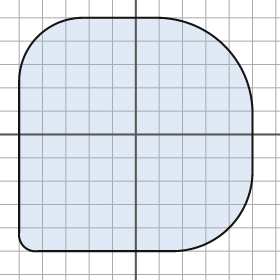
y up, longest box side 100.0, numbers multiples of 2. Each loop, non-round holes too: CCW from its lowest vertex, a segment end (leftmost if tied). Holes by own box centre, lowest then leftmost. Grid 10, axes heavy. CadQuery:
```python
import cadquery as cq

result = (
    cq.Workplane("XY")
    .moveTo(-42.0, -50.0)
    .lineTo(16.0, -50.0)
    .threePointArc((40.0, -40.0), (50.0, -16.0))
    .lineTo(50.0, 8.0)
    .threePointArc((38.0, 38.0), (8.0, 50.0))
    .lineTo(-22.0, 50.0)
    .threePointArc((-42.0, 42.0), (-50.0, 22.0))
    .lineTo(-50.0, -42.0)
    .threePointArc((-48.0, -48.0), (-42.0, -50.0))
    .close()
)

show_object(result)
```